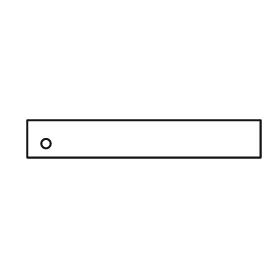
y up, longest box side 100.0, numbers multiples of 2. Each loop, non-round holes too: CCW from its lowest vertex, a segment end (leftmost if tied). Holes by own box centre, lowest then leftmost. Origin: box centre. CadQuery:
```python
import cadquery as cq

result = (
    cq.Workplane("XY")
    .moveTo(-50.0, -8.0)
    .lineTo(50.0, -8.0)
    .lineTo(50.0, 8.0)
    .lineTo(-50.0, 8.0)
    .close()
    .moveTo(-42.0, -2.0)
    .circle(2.0)
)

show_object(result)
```